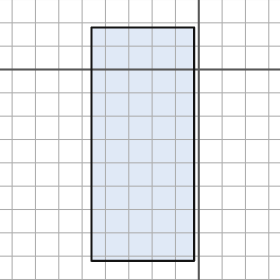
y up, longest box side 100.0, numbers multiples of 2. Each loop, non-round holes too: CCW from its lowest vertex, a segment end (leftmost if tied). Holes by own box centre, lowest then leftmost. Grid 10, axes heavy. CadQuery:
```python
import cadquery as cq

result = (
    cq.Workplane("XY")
    .moveTo(-46.0, -82.0)
    .lineTo(-2.0, -82.0)
    .lineTo(-2.0, 18.0)
    .lineTo(-46.0, 18.0)
    .close()
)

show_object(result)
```